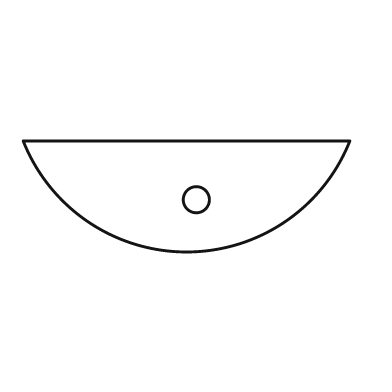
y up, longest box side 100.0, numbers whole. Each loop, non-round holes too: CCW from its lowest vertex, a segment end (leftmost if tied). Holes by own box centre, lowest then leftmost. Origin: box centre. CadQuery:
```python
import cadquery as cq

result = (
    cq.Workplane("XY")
    .moveTo(-50.0, 17.0)
    .threePointArc((0.0, -17.0), (50.0, 17.0))
    .close()
    .moveTo(3.0, -1.0)
    .circle(4.0)
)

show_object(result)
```